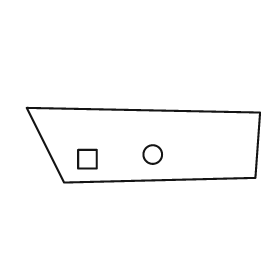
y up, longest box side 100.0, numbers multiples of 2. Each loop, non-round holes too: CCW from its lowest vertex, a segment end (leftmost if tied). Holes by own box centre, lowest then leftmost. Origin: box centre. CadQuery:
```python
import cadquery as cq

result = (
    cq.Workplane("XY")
    .moveTo(-34.0, -16.0)
    .lineTo(48.0, -14.0)
    .lineTo(50.0, 14.0)
    .lineTo(-50.0, 16.0)
    .close()
    .moveTo(-28.0, -10.0)
    .lineTo(-20.0, -10.0)
    .lineTo(-20.0, -2.0)
    .lineTo(-28.0, -2.0)
    .close()
    .moveTo(4.0, -4.0)
    .circle(4.0)
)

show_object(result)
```